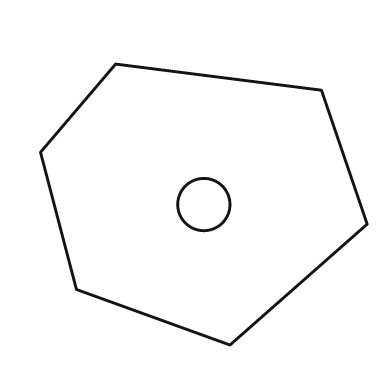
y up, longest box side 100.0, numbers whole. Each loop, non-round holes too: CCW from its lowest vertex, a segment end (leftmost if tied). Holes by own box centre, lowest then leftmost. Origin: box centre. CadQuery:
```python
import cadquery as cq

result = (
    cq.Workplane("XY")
    .moveTo(8.0, -43.0)
    .lineTo(50.0, -6.0)
    .lineTo(36.0, 35.0)
    .lineTo(-27.0, 43.0)
    .lineTo(-50.0, 16.0)
    .lineTo(-39.0, -26.0)
    .close()
    .moveTo(0.0, 0.0)
    .circle(8.0)
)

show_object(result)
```